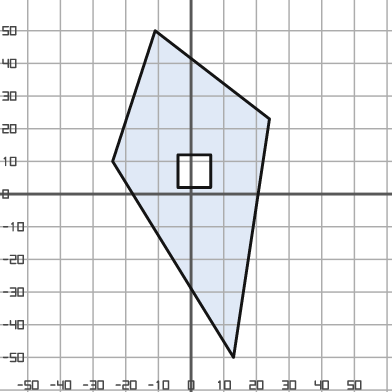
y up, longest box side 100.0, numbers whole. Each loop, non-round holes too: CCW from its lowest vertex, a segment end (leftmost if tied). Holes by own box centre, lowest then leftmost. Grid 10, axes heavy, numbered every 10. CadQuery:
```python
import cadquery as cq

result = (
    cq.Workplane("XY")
    .moveTo(13.0, -50.0)
    .lineTo(24.0, 23.0)
    .lineTo(-11.0, 50.0)
    .lineTo(-24.0, 10.0)
    .close()
    .moveTo(-4.0, 2.0)
    .lineTo(6.0, 2.0)
    .lineTo(6.0, 12.0)
    .lineTo(-4.0, 12.0)
    .close()
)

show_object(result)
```